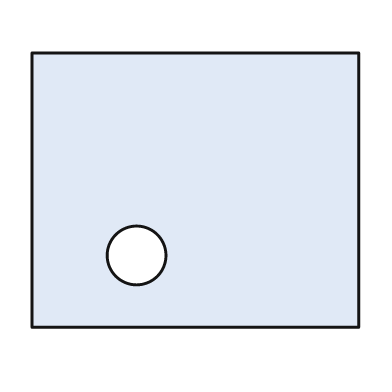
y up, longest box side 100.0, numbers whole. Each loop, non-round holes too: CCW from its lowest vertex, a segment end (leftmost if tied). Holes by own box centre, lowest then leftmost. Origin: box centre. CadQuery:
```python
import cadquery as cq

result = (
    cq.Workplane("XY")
    .moveTo(-50.0, -42.0)
    .lineTo(50.0, -42.0)
    .lineTo(50.0, 42.0)
    .lineTo(-50.0, 42.0)
    .close()
    .moveTo(-18.0, -20.0)
    .circle(9.0)
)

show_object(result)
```